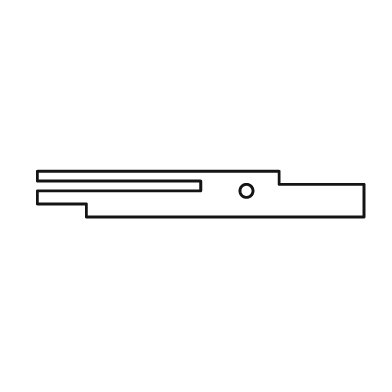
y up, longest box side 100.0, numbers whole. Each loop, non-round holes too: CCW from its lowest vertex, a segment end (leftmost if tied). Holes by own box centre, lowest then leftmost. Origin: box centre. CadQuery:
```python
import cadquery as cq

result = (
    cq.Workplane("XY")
    .moveTo(-35.0, -7.0)
    .lineTo(50.0, -7.0)
    .lineTo(50.0, 3.0)
    .lineTo(24.0, 3.0)
    .lineTo(24.0, 7.0)
    .lineTo(-50.0, 7.0)
    .lineTo(-50.0, 4.0)
    .lineTo(0.0, 4.0)
    .lineTo(0.0, 1.0)
    .lineTo(-50.0, 1.0)
    .lineTo(-50.0, -3.0)
    .lineTo(-35.0, -3.0)
    .close()
    .moveTo(14.0, 1.0)
    .circle(2.0)
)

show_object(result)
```